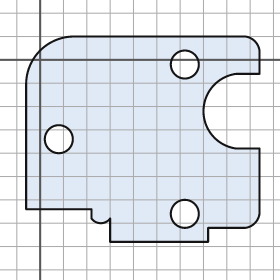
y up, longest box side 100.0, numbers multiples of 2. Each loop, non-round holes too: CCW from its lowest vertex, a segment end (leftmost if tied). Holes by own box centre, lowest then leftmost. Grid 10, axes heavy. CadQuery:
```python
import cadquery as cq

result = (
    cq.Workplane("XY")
    .moveTo(30.0, -78.0)
    .lineTo(72.0, -78.0)
    .lineTo(72.0, -72.0)
    .lineTo(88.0, -72.0)
    .threePointArc((92.0, -70.0), (94.0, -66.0))
    .lineTo(94.0, -38.0)
    .lineTo(84.0, -38.0)
    .threePointArc((70.0, -22.0), (84.0, -6.0))
    .lineTo(94.0, -6.0)
    .lineTo(94.0, 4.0)
    .threePointArc((92.0, 8.0), (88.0, 10.0))
    .lineTo(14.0, 10.0)
    .threePointArc((0.0, 4.0), (-6.0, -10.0))
    .lineTo(-6.0, -64.0)
    .lineTo(22.0, -64.0)
    .lineTo(22.0, -68.0)
    .threePointArc((26.0, -70.0), (30.0, -68.0))
    .close()
    .moveTo(62.0, -66.0)
    .circle(6.0)
    .moveTo(8.0, -34.0)
    .circle(6.0)
    .moveTo(62.0, -2.0)
    .circle(6.0)
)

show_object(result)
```